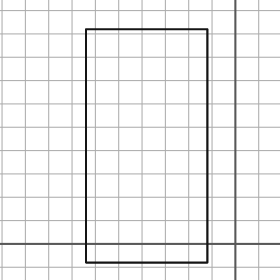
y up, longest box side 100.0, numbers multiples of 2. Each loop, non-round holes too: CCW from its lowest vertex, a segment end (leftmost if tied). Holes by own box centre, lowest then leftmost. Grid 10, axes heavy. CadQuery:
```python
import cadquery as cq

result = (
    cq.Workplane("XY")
    .moveTo(-64.0, -8.0)
    .lineTo(-12.0, -8.0)
    .lineTo(-12.0, 92.0)
    .lineTo(-64.0, 92.0)
    .close()
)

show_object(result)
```